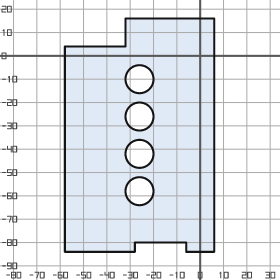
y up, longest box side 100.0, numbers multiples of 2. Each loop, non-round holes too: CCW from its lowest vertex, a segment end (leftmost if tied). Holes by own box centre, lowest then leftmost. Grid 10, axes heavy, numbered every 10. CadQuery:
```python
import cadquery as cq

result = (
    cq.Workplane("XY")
    .moveTo(-58.0, -84.0)
    .lineTo(-28.0, -84.0)
    .lineTo(-28.0, -80.0)
    .lineTo(-6.0, -80.0)
    .lineTo(-6.0, -84.0)
    .lineTo(6.0, -84.0)
    .lineTo(6.0, 16.0)
    .lineTo(-32.0, 16.0)
    .lineTo(-32.0, 4.0)
    .lineTo(-58.0, 4.0)
    .close()
    .moveTo(-26.0, -58.0)
    .circle(6.0)
    .moveTo(-26.0, -42.0)
    .circle(6.0)
    .moveTo(-26.0, -26.0)
    .circle(6.0)
    .moveTo(-26.0, -10.0)
    .circle(6.0)
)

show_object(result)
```